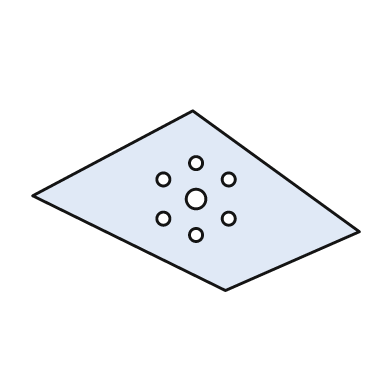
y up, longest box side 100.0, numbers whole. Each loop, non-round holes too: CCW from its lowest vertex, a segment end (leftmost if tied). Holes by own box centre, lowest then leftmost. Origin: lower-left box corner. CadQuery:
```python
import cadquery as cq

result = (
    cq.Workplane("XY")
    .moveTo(59.0, 0.0)
    .lineTo(100.0, 18.0)
    .lineTo(49.0, 55.0)
    .lineTo(0.0, 29.0)
    .close()
    .moveTo(50.0, 17.0)
    .circle(2.0)
    .moveTo(40.0, 22.0)
    .circle(2.0)
    .moveTo(60.0, 22.0)
    .circle(2.0)
    .moveTo(50.0, 28.0)
    .circle(3.0)
    .moveTo(40.0, 34.0)
    .circle(2.0)
    .moveTo(60.0, 34.0)
    .circle(2.0)
    .moveTo(50.0, 39.0)
    .circle(2.0)
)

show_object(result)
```